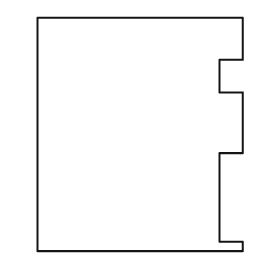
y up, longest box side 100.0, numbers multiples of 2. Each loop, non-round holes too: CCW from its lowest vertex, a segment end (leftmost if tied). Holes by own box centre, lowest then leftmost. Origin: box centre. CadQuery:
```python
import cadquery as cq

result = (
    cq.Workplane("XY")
    .moveTo(-44.0, -50.0)
    .lineTo(44.0, -50.0)
    .lineTo(44.0, -46.0)
    .lineTo(34.0, -46.0)
    .lineTo(34.0, -8.0)
    .lineTo(44.0, -8.0)
    .lineTo(44.0, 18.0)
    .lineTo(34.0, 18.0)
    .lineTo(34.0, 32.0)
    .lineTo(44.0, 32.0)
    .lineTo(44.0, 50.0)
    .lineTo(-44.0, 50.0)
    .close()
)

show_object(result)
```